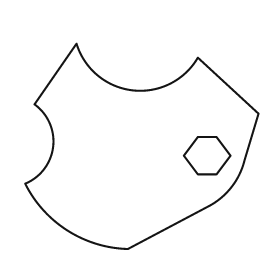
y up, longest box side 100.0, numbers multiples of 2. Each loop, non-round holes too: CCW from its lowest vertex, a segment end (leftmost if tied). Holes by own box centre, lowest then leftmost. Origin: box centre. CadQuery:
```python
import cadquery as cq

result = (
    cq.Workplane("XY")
    .moveTo(-6.0, -44.0)
    .lineTo(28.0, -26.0)
    .threePointArc((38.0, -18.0), (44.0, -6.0))
    .lineTo(50.0, 14.0)
    .lineTo(24.0, 38.0)
    .threePointArc((-4.0, 24.0), (-28.0, 44.0))
    .lineTo(-46.0, 18.0)
    .threePointArc((-38.0, 0.0), (-50.0, -16.0))
    .threePointArc((-32.0, -36.0), (-6.0, -44.0))
    .close()
    .moveTo(24.0, -12.0)
    .lineTo(32.0, -12.0)
    .lineTo(38.0, -4.0)
    .lineTo(32.0, 4.0)
    .lineTo(24.0, 4.0)
    .lineTo(18.0, -4.0)
    .close()
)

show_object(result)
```